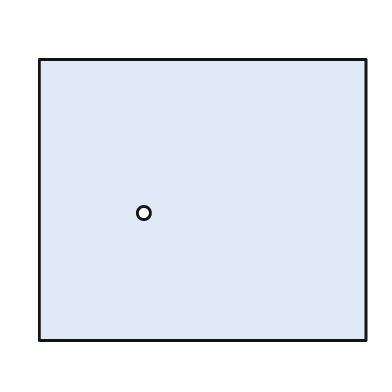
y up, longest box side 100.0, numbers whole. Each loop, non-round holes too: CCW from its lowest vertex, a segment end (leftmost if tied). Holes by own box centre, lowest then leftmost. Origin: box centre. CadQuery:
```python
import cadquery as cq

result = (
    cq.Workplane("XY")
    .moveTo(-50.0, -43.0)
    .lineTo(50.0, -43.0)
    .lineTo(50.0, 43.0)
    .lineTo(-50.0, 43.0)
    .close()
    .moveTo(-18.0, -4.0)
    .circle(2.0)
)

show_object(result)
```